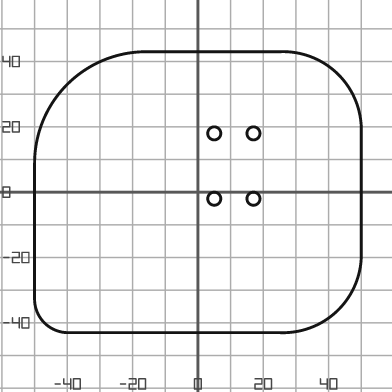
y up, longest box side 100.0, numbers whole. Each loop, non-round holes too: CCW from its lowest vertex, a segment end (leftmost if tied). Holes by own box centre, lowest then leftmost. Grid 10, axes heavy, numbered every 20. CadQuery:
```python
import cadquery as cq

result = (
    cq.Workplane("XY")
    .moveTo(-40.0, -43.0)
    .lineTo(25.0, -43.0)
    .threePointArc((43.0, -36.0), (50.0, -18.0))
    .lineTo(50.0, 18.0)
    .threePointArc((43.0, 36.0), (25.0, 43.0))
    .lineTo(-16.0, 43.0)
    .threePointArc((-40.0, 33.0), (-50.0, 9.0))
    .lineTo(-50.0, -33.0)
    .threePointArc((-47.0, -40.0), (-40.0, -43.0))
    .close()
    .moveTo(5.0, -2.0)
    .circle(2.0)
    .moveTo(17.0, -2.0)
    .circle(2.0)
    .moveTo(5.0, 18.0)
    .circle(2.0)
    .moveTo(17.0, 18.0)
    .circle(2.0)
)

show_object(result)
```